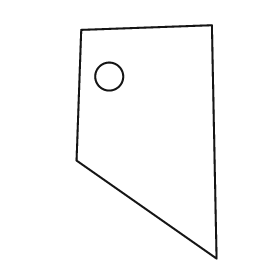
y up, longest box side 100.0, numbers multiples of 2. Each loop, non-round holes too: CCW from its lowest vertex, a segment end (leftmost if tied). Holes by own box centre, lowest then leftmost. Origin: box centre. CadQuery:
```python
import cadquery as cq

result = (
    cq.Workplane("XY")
    .moveTo(30.0, -50.0)
    .lineTo(28.0, 50.0)
    .lineTo(-28.0, 48.0)
    .lineTo(-30.0, -8.0)
    .close()
    .moveTo(-16.0, 28.0)
    .circle(6.0)
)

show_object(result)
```